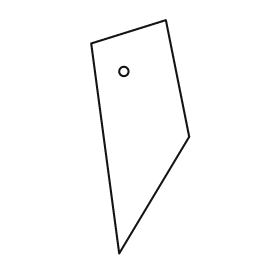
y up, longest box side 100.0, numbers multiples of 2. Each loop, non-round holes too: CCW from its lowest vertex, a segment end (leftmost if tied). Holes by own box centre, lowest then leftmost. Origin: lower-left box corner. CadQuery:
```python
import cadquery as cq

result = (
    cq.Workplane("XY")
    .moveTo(12.0, 0.0)
    .lineTo(42.0, 50.0)
    .lineTo(32.0, 100.0)
    .lineTo(0.0, 90.0)
    .close()
    .moveTo(14.0, 78.0)
    .circle(2.0)
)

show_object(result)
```